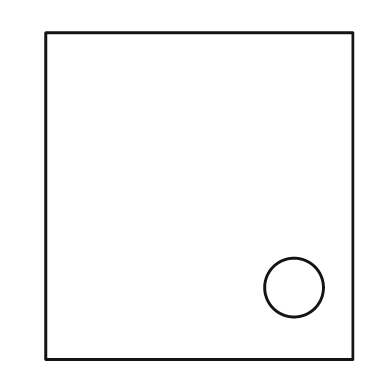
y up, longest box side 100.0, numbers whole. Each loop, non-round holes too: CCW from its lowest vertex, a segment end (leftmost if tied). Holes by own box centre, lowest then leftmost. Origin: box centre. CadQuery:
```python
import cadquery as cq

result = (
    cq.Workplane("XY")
    .moveTo(-47.0, -50.0)
    .lineTo(47.0, -50.0)
    .lineTo(47.0, 50.0)
    .lineTo(-47.0, 50.0)
    .close()
    .moveTo(29.0, -28.0)
    .circle(9.0)
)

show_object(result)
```